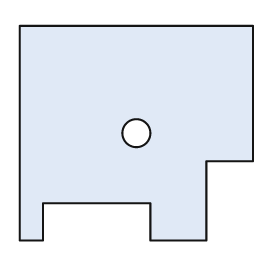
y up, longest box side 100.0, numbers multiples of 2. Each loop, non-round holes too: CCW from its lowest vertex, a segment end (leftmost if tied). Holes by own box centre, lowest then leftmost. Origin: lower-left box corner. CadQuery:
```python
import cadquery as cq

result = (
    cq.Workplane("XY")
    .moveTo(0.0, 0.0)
    .lineTo(10.0, 0.0)
    .lineTo(10.0, 16.0)
    .lineTo(56.0, 16.0)
    .lineTo(56.0, 0.0)
    .lineTo(80.0, 0.0)
    .lineTo(80.0, 34.0)
    .lineTo(100.0, 34.0)
    .lineTo(100.0, 92.0)
    .lineTo(0.0, 92.0)
    .close()
    .moveTo(50.0, 46.0)
    .circle(6.0)
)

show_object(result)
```